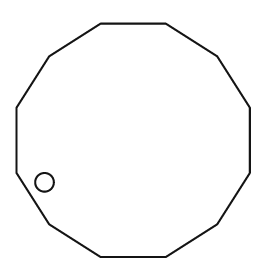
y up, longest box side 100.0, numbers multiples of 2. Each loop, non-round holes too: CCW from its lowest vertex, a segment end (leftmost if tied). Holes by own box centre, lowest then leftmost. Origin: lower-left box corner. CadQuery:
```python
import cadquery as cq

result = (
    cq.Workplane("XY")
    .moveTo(36.0, 0.0)
    .lineTo(64.0, 0.0)
    .lineTo(86.0, 14.0)
    .lineTo(100.0, 36.0)
    .lineTo(100.0, 64.0)
    .lineTo(86.0, 86.0)
    .lineTo(64.0, 100.0)
    .lineTo(36.0, 100.0)
    .lineTo(14.0, 86.0)
    .lineTo(0.0, 64.0)
    .lineTo(0.0, 36.0)
    .lineTo(14.0, 14.0)
    .close()
    .moveTo(12.0, 32.0)
    .circle(4.0)
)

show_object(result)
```